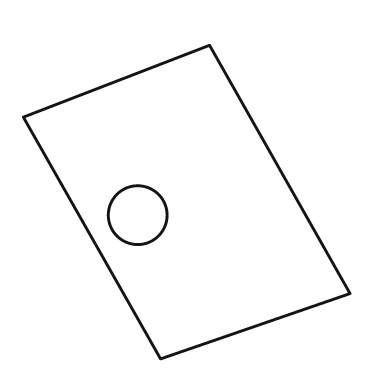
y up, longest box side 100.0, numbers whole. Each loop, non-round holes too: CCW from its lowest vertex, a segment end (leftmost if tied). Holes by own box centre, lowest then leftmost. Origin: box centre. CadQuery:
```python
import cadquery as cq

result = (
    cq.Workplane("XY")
    .moveTo(-8.0, -48.0)
    .lineTo(50.0, -28.0)
    .lineTo(7.0, 48.0)
    .lineTo(-50.0, 26.0)
    .close()
    .moveTo(-15.0, -4.0)
    .circle(9.0)
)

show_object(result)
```